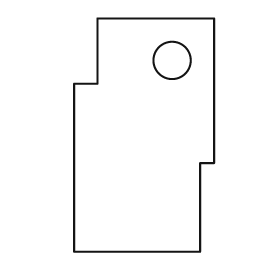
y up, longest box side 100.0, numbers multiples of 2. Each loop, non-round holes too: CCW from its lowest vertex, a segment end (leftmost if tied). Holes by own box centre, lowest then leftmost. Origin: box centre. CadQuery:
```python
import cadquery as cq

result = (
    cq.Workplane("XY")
    .moveTo(-30.0, -50.0)
    .lineTo(24.0, -50.0)
    .lineTo(24.0, -12.0)
    .lineTo(30.0, -12.0)
    .lineTo(30.0, 50.0)
    .lineTo(-20.0, 50.0)
    .lineTo(-20.0, 22.0)
    .lineTo(-30.0, 22.0)
    .close()
    .moveTo(12.0, 32.0)
    .circle(8.0)
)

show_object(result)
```